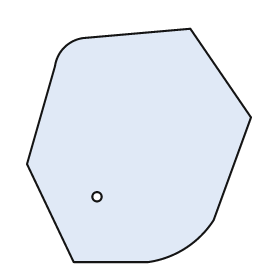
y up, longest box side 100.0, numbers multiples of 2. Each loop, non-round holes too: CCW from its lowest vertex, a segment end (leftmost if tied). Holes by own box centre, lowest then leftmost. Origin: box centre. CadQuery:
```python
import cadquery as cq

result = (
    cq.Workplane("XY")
    .moveTo(-28.0, -50.0)
    .lineTo(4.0, -50.0)
    .threePointArc((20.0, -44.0), (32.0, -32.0))
    .lineTo(48.0, 12.0)
    .lineTo(22.0, 50.0)
    .lineTo(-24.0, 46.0)
    .threePointArc((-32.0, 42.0), (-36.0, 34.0))
    .lineTo(-48.0, -8.0)
    .close()
    .moveTo(-18.0, -22.0)
    .circle(2.0)
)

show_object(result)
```